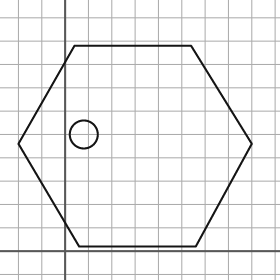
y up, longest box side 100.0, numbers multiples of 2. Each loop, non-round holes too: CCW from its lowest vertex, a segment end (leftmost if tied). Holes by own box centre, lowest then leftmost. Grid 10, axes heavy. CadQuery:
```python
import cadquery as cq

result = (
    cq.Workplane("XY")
    .moveTo(6.0, 2.0)
    .lineTo(56.0, 2.0)
    .lineTo(80.0, 46.0)
    .lineTo(54.0, 88.0)
    .lineTo(4.0, 88.0)
    .lineTo(-20.0, 46.0)
    .close()
    .moveTo(8.0, 50.0)
    .circle(6.0)
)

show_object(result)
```